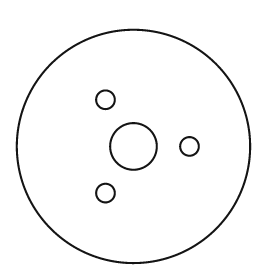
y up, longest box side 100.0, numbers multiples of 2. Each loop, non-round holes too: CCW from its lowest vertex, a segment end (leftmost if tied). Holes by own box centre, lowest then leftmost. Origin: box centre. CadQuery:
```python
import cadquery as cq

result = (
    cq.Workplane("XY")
    .moveTo(0.0, 0.0)
    .circle(50.0)
    .moveTo(-12.0, -20.0)
    .circle(4.0)
    .moveTo(0.0, 0.0)
    .circle(10.0)
    .moveTo(24.0, 0.0)
    .circle(4.0)
    .moveTo(-12.0, 20.0)
    .circle(4.0)
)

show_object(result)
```